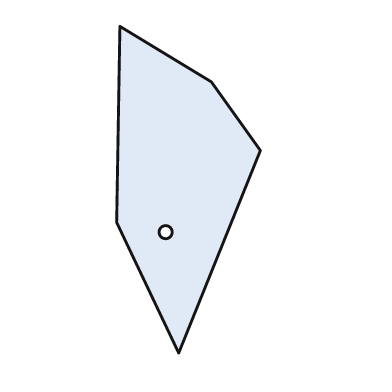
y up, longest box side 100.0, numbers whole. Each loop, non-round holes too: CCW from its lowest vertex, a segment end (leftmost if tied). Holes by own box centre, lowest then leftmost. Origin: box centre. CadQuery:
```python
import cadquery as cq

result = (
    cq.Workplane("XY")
    .moveTo(-3.0, -50.0)
    .lineTo(22.0, 12.0)
    .lineTo(7.0, 33.0)
    .lineTo(-21.0, 50.0)
    .lineTo(-22.0, -10.0)
    .close()
    .moveTo(-7.0, -13.0)
    .circle(2.0)
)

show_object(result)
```